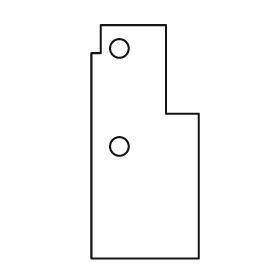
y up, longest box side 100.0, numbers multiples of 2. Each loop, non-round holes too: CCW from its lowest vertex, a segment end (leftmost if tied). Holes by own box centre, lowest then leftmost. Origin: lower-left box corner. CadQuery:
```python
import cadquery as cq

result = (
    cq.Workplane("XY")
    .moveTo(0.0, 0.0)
    .lineTo(46.0, 0.0)
    .lineTo(46.0, 62.0)
    .lineTo(32.0, 62.0)
    .lineTo(32.0, 100.0)
    .lineTo(4.0, 100.0)
    .lineTo(4.0, 88.0)
    .lineTo(0.0, 88.0)
    .close()
    .moveTo(12.0, 48.0)
    .circle(4.0)
    .moveTo(12.0, 90.0)
    .circle(4.0)
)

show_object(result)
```